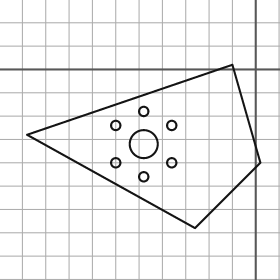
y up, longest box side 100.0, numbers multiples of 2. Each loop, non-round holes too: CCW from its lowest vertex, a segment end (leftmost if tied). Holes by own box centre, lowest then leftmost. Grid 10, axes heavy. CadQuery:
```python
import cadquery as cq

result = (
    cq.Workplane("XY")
    .moveTo(-26.0, -68.0)
    .lineTo(2.0, -40.0)
    .lineTo(-10.0, 2.0)
    .lineTo(-98.0, -28.0)
    .close()
    .moveTo(-48.0, -46.0)
    .circle(2.0)
    .moveTo(-60.0, -40.0)
    .circle(2.0)
    .moveTo(-36.0, -40.0)
    .circle(2.0)
    .moveTo(-48.0, -32.0)
    .circle(6.0)
    .moveTo(-60.0, -24.0)
    .circle(2.0)
    .moveTo(-36.0, -24.0)
    .circle(2.0)
    .moveTo(-48.0, -18.0)
    .circle(2.0)
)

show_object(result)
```